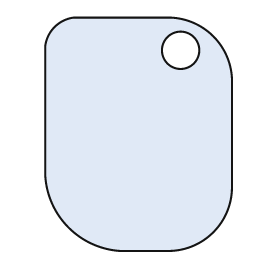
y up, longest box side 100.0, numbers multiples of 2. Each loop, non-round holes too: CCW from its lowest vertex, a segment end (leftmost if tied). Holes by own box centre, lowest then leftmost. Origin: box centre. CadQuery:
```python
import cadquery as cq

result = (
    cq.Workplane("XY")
    .moveTo(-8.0, -50.0)
    .lineTo(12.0, -50.0)
    .threePointArc((32.0, -42.0), (40.0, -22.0))
    .lineTo(40.0, 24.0)
    .threePointArc((32.0, 42.0), (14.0, 50.0))
    .lineTo(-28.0, 50.0)
    .threePointArc((-36.0, 46.0), (-40.0, 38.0))
    .lineTo(-40.0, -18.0)
    .threePointArc((-30.0, -40.0), (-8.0, -50.0))
    .close()
    .moveTo(18.0, 36.0)
    .circle(8.0)
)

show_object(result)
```